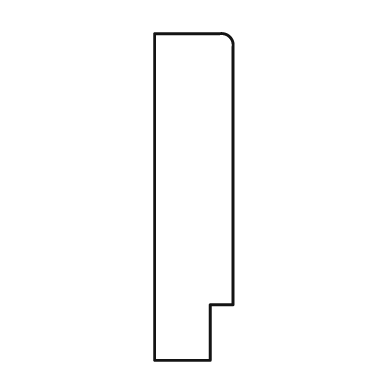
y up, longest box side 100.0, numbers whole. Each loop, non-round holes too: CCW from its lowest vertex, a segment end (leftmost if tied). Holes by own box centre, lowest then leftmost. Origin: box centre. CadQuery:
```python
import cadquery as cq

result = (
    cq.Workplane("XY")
    .moveTo(-12.0, -50.0)
    .lineTo(5.0, -50.0)
    .lineTo(5.0, -33.0)
    .lineTo(12.0, -33.0)
    .lineTo(12.0, 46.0)
    .threePointArc((11.0, 49.0), (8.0, 50.0))
    .lineTo(-12.0, 50.0)
    .close()
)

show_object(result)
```